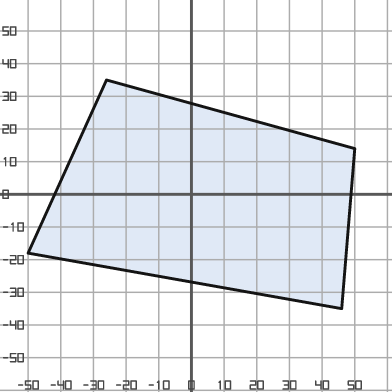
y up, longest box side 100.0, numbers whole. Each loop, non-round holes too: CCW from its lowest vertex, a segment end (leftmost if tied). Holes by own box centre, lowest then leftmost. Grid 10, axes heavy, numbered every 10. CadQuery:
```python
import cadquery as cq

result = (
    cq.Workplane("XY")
    .moveTo(46.0, -35.0)
    .lineTo(50.0, 14.0)
    .lineTo(-26.0, 35.0)
    .lineTo(-50.0, -18.0)
    .close()
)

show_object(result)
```